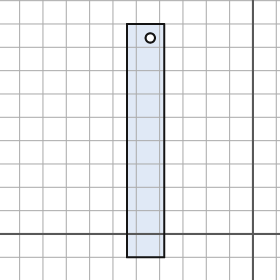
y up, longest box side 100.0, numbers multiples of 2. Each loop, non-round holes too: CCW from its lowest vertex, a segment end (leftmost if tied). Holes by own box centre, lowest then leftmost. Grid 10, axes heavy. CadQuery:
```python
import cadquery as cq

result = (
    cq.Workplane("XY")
    .moveTo(-54.0, -10.0)
    .lineTo(-38.0, -10.0)
    .lineTo(-38.0, 90.0)
    .lineTo(-54.0, 90.0)
    .close()
    .moveTo(-44.0, 84.0)
    .circle(2.0)
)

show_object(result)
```